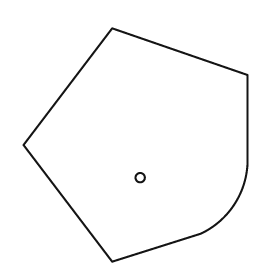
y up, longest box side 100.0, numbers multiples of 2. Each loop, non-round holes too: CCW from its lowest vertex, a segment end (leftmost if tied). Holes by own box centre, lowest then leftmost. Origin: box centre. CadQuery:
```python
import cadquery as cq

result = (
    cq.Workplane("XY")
    .moveTo(-10.0, -50.0)
    .lineTo(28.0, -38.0)
    .threePointArc((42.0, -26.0), (48.0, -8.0))
    .lineTo(48.0, 30.0)
    .lineTo(-10.0, 50.0)
    .lineTo(-48.0, 0.0)
    .close()
    .moveTo(2.0, -14.0)
    .circle(2.0)
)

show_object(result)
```